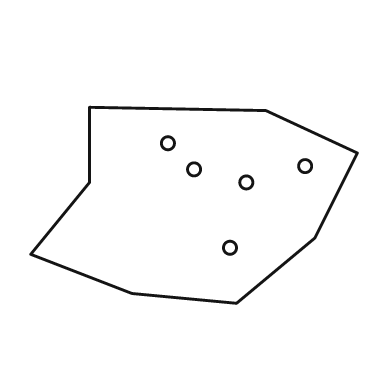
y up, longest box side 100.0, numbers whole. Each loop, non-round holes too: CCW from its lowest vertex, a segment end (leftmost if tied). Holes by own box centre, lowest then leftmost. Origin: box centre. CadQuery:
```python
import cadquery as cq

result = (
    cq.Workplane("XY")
    .moveTo(13.0, -30.0)
    .lineTo(37.0, -10.0)
    .lineTo(50.0, 16.0)
    .lineTo(22.0, 29.0)
    .lineTo(-32.0, 30.0)
    .lineTo(-32.0, 7.0)
    .lineTo(-50.0, -15.0)
    .lineTo(-19.0, -27.0)
    .close()
    .moveTo(11.0, -13.0)
    .circle(2.0)
    .moveTo(16.0, 7.0)
    .circle(2.0)
    .moveTo(0.0, 11.0)
    .circle(2.0)
    .moveTo(34.0, 12.0)
    .circle(2.0)
    .moveTo(-8.0, 19.0)
    .circle(2.0)
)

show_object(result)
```